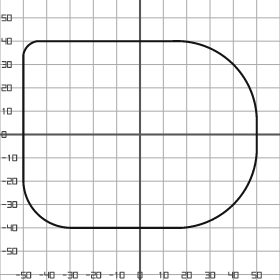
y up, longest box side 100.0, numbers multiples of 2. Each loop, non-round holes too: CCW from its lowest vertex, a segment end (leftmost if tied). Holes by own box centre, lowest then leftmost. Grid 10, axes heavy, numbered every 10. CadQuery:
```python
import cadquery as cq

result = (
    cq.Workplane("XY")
    .moveTo(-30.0, -40.0)
    .lineTo(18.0, -40.0)
    .threePointArc((40.0, -30.0), (50.0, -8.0))
    .lineTo(50.0, 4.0)
    .threePointArc((40.0, 30.0), (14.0, 40.0))
    .lineTo(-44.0, 40.0)
    .threePointArc((-48.0, 38.0), (-50.0, 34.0))
    .lineTo(-50.0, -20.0)
    .threePointArc((-44.0, -34.0), (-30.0, -40.0))
    .close()
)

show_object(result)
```